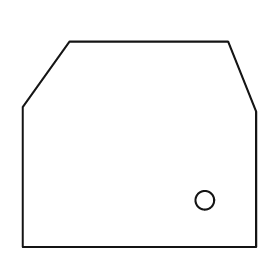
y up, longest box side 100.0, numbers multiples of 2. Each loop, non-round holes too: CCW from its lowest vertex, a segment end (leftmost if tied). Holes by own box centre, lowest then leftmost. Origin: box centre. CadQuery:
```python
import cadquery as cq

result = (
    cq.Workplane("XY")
    .moveTo(-50.0, -44.0)
    .lineTo(50.0, -44.0)
    .lineTo(50.0, 14.0)
    .lineTo(38.0, 44.0)
    .lineTo(-30.0, 44.0)
    .lineTo(-50.0, 16.0)
    .close()
    .moveTo(28.0, -24.0)
    .circle(4.0)
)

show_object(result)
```